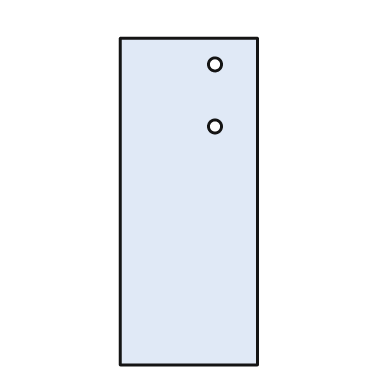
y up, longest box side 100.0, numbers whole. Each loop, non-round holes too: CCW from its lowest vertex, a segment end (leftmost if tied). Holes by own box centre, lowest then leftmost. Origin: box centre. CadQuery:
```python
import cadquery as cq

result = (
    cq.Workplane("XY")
    .moveTo(-21.0, -50.0)
    .lineTo(21.0, -50.0)
    .lineTo(21.0, 50.0)
    .lineTo(-21.0, 50.0)
    .close()
    .moveTo(8.0, 23.0)
    .circle(2.0)
    .moveTo(8.0, 42.0)
    .circle(2.0)
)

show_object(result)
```